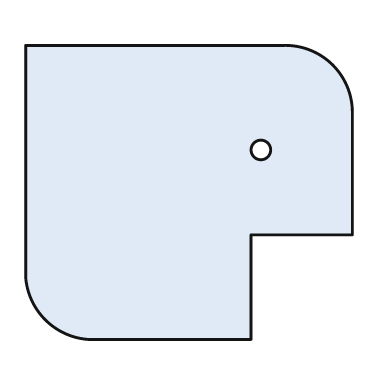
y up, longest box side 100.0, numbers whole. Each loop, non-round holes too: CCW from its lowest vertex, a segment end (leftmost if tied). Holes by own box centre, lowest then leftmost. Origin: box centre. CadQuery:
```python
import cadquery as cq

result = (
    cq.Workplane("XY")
    .moveTo(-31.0, -45.0)
    .lineTo(19.0, -45.0)
    .lineTo(19.0, -13.0)
    .lineTo(50.0, -13.0)
    .lineTo(50.0, 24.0)
    .threePointArc((44.0, 39.0), (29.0, 45.0))
    .lineTo(-50.0, 45.0)
    .lineTo(-50.0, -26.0)
    .threePointArc((-44.0, -39.0), (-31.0, -45.0))
    .close()
    .moveTo(22.0, 13.0)
    .circle(3.0)
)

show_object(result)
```